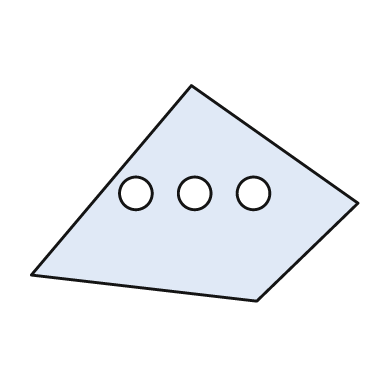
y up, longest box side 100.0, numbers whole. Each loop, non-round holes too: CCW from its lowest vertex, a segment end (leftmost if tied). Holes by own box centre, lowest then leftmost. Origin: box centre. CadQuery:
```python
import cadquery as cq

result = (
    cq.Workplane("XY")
    .moveTo(19.0, -33.0)
    .lineTo(50.0, -3.0)
    .lineTo(-1.0, 33.0)
    .lineTo(-50.0, -25.0)
    .close()
    .moveTo(-18.0, 0.0)
    .circle(5.0)
    .moveTo(0.0, 0.0)
    .circle(5.0)
    .moveTo(18.0, 0.0)
    .circle(5.0)
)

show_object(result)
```